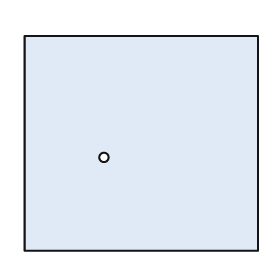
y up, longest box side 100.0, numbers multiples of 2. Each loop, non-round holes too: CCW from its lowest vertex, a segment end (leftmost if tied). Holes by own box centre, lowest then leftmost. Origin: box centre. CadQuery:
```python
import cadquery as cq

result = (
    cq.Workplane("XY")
    .moveTo(-50.0, -46.0)
    .lineTo(50.0, -46.0)
    .lineTo(50.0, 46.0)
    .lineTo(-50.0, 46.0)
    .close()
    .moveTo(-16.0, -6.0)
    .circle(2.0)
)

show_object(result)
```